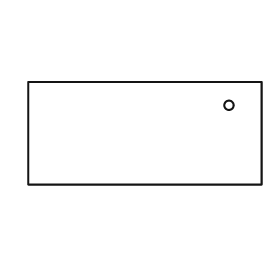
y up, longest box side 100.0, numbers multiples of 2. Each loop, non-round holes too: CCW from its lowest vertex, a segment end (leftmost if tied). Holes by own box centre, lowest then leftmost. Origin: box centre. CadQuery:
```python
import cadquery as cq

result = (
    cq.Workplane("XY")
    .moveTo(-50.0, -22.0)
    .lineTo(50.0, -22.0)
    .lineTo(50.0, 22.0)
    .lineTo(-50.0, 22.0)
    .close()
    .moveTo(36.0, 12.0)
    .circle(2.0)
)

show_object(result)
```